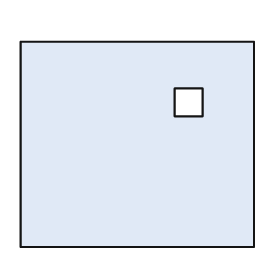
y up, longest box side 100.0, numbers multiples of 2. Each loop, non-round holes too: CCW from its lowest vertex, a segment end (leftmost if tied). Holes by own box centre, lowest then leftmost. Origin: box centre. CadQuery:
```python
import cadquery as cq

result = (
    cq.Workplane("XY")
    .moveTo(-50.0, -44.0)
    .lineTo(50.0, -44.0)
    .lineTo(50.0, 44.0)
    .lineTo(-50.0, 44.0)
    .close()
    .moveTo(16.0, 12.0)
    .lineTo(28.0, 12.0)
    .lineTo(28.0, 24.0)
    .lineTo(16.0, 24.0)
    .close()
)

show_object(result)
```